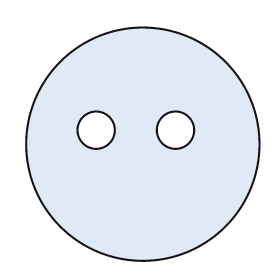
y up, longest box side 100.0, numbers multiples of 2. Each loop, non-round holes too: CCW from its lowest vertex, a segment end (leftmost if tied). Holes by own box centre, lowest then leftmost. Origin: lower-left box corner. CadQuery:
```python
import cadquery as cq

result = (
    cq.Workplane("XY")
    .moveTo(50.0, 50.0)
    .circle(50.0)
    .moveTo(30.0, 56.0)
    .circle(8.0)
    .moveTo(64.0, 56.0)
    .circle(8.0)
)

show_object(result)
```